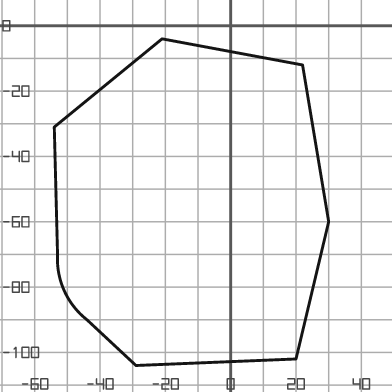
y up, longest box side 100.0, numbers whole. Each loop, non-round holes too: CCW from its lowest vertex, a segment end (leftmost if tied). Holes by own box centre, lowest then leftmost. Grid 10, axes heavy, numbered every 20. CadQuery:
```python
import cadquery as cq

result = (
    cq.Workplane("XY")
    .moveTo(-29.0, -104.0)
    .lineTo(20.0, -102.0)
    .lineTo(30.0, -60.0)
    .lineTo(22.0, -12.0)
    .lineTo(-21.0, -4.0)
    .lineTo(-54.0, -31.0)
    .lineTo(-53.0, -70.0)
    .threePointArc((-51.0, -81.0), (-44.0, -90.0))
    .close()
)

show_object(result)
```